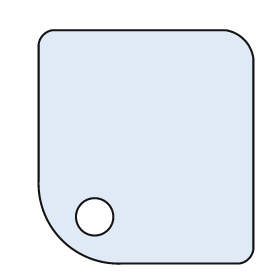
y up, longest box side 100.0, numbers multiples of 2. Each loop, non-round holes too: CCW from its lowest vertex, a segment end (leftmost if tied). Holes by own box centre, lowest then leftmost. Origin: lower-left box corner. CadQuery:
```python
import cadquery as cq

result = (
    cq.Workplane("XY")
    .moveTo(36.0, 0.0)
    .lineTo(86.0, 0.0)
    .threePointArc((90.0, 2.0), (92.0, 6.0))
    .lineTo(92.0, 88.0)
    .threePointArc((88.0, 96.0), (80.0, 100.0))
    .lineTo(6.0, 100.0)
    .threePointArc((2.0, 98.0), (0.0, 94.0))
    .lineTo(0.0, 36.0)
    .threePointArc((10.0, 10.0), (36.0, 0.0))
    .close()
    .moveTo(24.0, 20.0)
    .circle(8.0)
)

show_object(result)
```